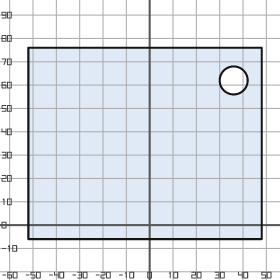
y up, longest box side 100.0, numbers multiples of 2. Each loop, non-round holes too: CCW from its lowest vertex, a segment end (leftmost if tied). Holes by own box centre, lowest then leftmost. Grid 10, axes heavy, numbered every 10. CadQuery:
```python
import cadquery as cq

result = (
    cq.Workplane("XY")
    .moveTo(-52.0, -6.0)
    .lineTo(48.0, -6.0)
    .lineTo(48.0, 76.0)
    .lineTo(-52.0, 76.0)
    .close()
    .moveTo(36.0, 62.0)
    .circle(6.0)
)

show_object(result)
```